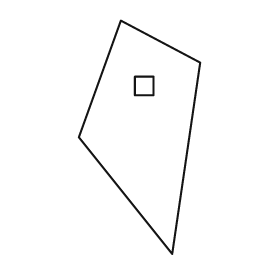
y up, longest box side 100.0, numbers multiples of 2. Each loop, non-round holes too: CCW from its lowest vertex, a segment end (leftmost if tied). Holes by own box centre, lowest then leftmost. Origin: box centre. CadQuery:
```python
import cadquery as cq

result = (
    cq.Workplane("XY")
    .moveTo(14.0, -50.0)
    .lineTo(26.0, 32.0)
    .lineTo(-8.0, 50.0)
    .lineTo(-26.0, 0.0)
    .close()
    .moveTo(-2.0, 18.0)
    .lineTo(6.0, 18.0)
    .lineTo(6.0, 26.0)
    .lineTo(-2.0, 26.0)
    .close()
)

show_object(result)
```